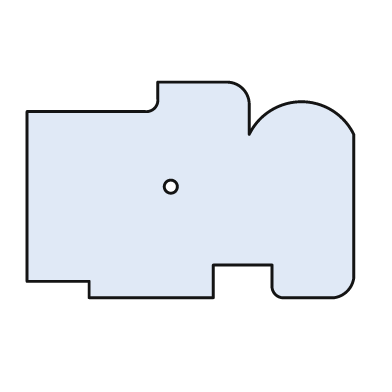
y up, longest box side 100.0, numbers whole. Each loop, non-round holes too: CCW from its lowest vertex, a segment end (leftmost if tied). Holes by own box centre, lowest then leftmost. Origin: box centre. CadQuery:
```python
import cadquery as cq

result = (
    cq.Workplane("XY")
    .moveTo(-31.0, -33.0)
    .lineTo(7.0, -33.0)
    .lineTo(7.0, -23.0)
    .lineTo(25.0, -23.0)
    .lineTo(25.0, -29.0)
    .threePointArc((26.0, -32.0), (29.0, -33.0))
    .lineTo(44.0, -33.0)
    .threePointArc((48.0, -31.0), (50.0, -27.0))
    .lineTo(50.0, 17.0)
    .threePointArc((34.0, 27.0), (18.0, 17.0))
    .lineTo(18.0, 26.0)
    .threePointArc((16.0, 31.0), (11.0, 33.0))
    .lineTo(-10.0, 33.0)
    .lineTo(-10.0, 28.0)
    .threePointArc((-11.0, 25.0), (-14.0, 24.0))
    .lineTo(-50.0, 24.0)
    .lineTo(-50.0, -28.0)
    .lineTo(-31.0, -28.0)
    .close()
    .moveTo(-6.0, 1.0)
    .circle(2.0)
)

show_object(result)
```